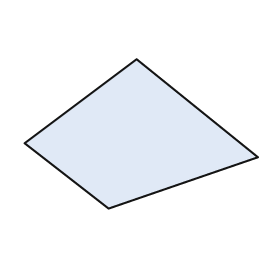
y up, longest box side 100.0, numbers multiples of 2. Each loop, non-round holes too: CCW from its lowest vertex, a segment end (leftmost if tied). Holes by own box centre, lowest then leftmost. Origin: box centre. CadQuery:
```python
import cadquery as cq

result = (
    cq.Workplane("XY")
    .moveTo(-14.0, -32.0)
    .lineTo(50.0, -10.0)
    .lineTo(-2.0, 32.0)
    .lineTo(-50.0, -4.0)
    .close()
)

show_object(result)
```